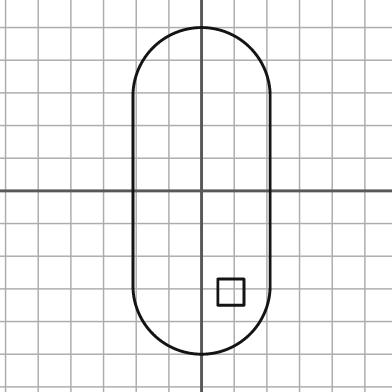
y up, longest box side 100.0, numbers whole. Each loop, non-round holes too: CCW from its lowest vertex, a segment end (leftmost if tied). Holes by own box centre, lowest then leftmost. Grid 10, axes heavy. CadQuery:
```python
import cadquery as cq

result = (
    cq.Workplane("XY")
    .moveTo(-21.0, -29.0)
    .threePointArc((0.0, -50.0), (21.0, -29.0))
    .lineTo(21.0, 29.0)
    .threePointArc((0.0, 50.0), (-21.0, 29.0))
    .close()
    .moveTo(5.0, -35.0)
    .lineTo(13.0, -35.0)
    .lineTo(13.0, -27.0)
    .lineTo(5.0, -27.0)
    .close()
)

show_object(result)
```